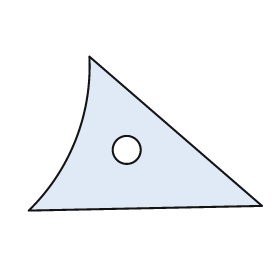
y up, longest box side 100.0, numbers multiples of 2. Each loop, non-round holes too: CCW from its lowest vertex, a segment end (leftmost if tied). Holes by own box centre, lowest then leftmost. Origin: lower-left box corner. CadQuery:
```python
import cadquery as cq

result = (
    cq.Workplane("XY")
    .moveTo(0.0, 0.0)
    .lineTo(100.0, 2.0)
    .lineTo(26.0, 66.0)
    .threePointArc((20.0, 30.0), (0.0, 0.0))
    .close()
    .moveTo(42.0, 26.0)
    .circle(6.0)
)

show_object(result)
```